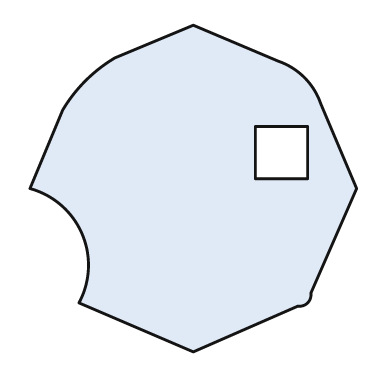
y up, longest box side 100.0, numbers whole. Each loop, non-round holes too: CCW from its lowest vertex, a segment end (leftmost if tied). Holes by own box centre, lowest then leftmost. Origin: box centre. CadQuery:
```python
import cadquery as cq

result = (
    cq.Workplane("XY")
    .moveTo(0.0, -50.0)
    .lineTo(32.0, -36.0)
    .threePointArc((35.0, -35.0), (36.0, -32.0))
    .lineTo(50.0, 0.0)
    .lineTo(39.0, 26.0)
    .threePointArc((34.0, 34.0), (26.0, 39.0))
    .lineTo(0.0, 50.0)
    .lineTo(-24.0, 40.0)
    .threePointArc((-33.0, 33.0), (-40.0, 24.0))
    .lineTo(-50.0, 0.0)
    .threePointArc((-34.0, -14.0), (-35.0, -35.0))
    .close()
    .moveTo(19.0, 3.0)
    .lineTo(35.0, 3.0)
    .lineTo(35.0, 19.0)
    .lineTo(19.0, 19.0)
    .close()
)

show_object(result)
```